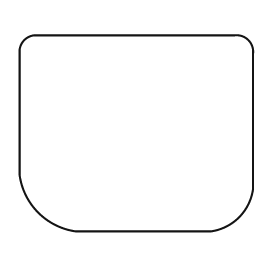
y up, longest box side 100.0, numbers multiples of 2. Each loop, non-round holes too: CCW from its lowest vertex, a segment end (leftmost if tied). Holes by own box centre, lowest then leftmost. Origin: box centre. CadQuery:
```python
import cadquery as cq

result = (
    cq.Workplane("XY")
    .moveTo(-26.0, -42.0)
    .lineTo(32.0, -42.0)
    .threePointArc((44.0, -36.0), (50.0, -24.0))
    .lineTo(50.0, 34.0)
    .threePointArc((48.0, 40.0), (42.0, 42.0))
    .lineTo(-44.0, 42.0)
    .threePointArc((-48.0, 40.0), (-50.0, 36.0))
    .lineTo(-50.0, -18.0)
    .threePointArc((-42.0, -34.0), (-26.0, -42.0))
    .close()
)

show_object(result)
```